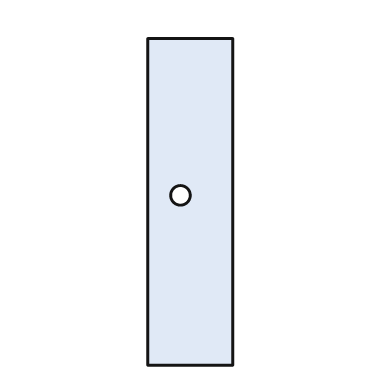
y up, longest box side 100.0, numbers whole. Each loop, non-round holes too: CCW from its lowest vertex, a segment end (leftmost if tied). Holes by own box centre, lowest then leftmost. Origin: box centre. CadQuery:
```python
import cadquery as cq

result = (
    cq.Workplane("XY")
    .moveTo(-13.0, -50.0)
    .lineTo(13.0, -50.0)
    .lineTo(13.0, 50.0)
    .lineTo(-13.0, 50.0)
    .close()
    .moveTo(-3.0, 2.0)
    .circle(3.0)
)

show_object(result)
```